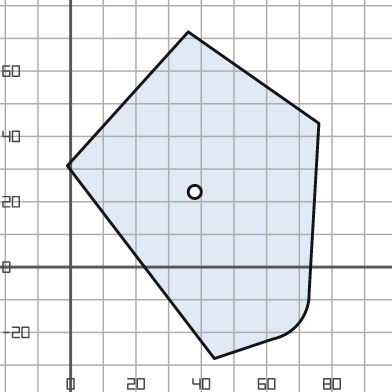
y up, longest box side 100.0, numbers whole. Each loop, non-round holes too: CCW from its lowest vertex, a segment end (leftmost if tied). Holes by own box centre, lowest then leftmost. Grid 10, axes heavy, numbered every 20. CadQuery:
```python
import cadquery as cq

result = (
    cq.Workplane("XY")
    .moveTo(44.0, -28.0)
    .lineTo(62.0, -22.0)
    .threePointArc((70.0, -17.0), (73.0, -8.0))
    .lineTo(76.0, 44.0)
    .lineTo(36.0, 72.0)
    .lineTo(-1.0, 31.0)
    .close()
    .moveTo(38.0, 23.0)
    .circle(2.0)
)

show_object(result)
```